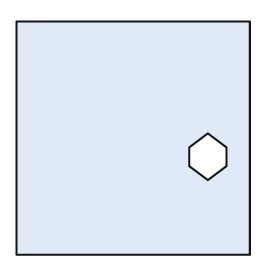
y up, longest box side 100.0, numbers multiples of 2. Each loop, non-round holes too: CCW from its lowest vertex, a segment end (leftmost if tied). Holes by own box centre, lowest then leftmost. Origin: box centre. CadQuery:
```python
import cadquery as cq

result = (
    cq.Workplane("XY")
    .moveTo(-50.0, -50.0)
    .lineTo(50.0, -50.0)
    .lineTo(50.0, 50.0)
    .lineTo(-50.0, 50.0)
    .close()
    .moveTo(32.0, -18.0)
    .lineTo(40.0, -12.0)
    .lineTo(40.0, -4.0)
    .lineTo(32.0, 2.0)
    .lineTo(24.0, -4.0)
    .lineTo(24.0, -12.0)
    .close()
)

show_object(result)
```